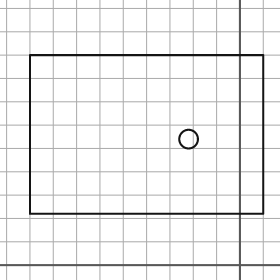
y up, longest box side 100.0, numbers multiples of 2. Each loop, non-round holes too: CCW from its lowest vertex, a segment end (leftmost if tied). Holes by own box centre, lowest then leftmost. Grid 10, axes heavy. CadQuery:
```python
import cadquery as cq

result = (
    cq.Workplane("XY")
    .moveTo(-90.0, 22.0)
    .lineTo(10.0, 22.0)
    .lineTo(10.0, 90.0)
    .lineTo(-90.0, 90.0)
    .close()
    .moveTo(-22.0, 54.0)
    .circle(4.0)
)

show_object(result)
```